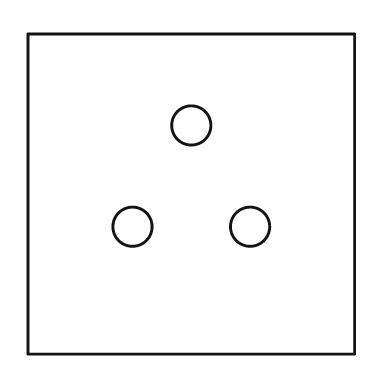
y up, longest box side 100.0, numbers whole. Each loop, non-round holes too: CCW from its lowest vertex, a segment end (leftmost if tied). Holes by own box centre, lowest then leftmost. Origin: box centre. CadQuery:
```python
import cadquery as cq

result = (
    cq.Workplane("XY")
    .moveTo(-50.0, -49.0)
    .lineTo(50.0, -49.0)
    .lineTo(50.0, 49.0)
    .lineTo(-50.0, 49.0)
    .close()
    .moveTo(-18.0, -10.0)
    .circle(6.0)
    .moveTo(18.0, -10.0)
    .circle(6.0)
    .moveTo(0.0, 21.0)
    .circle(6.0)
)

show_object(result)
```